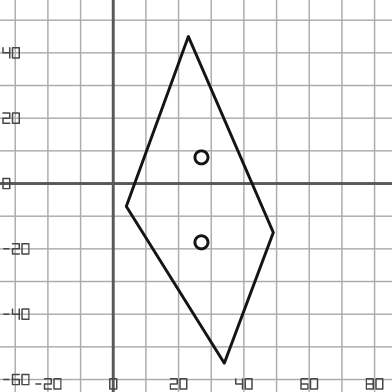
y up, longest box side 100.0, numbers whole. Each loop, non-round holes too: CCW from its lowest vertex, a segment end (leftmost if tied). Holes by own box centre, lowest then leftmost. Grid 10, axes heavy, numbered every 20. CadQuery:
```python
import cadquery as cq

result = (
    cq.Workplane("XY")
    .moveTo(34.0, -55.0)
    .lineTo(49.0, -15.0)
    .lineTo(23.0, 45.0)
    .lineTo(4.0, -7.0)
    .close()
    .moveTo(27.0, -18.0)
    .circle(2.0)
    .moveTo(27.0, 8.0)
    .circle(2.0)
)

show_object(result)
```